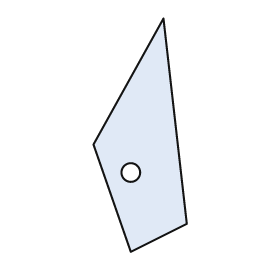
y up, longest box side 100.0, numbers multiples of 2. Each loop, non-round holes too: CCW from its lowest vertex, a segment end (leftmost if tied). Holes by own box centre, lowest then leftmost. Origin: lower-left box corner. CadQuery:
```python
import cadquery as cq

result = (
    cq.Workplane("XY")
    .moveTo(16.0, 0.0)
    .lineTo(40.0, 12.0)
    .lineTo(30.0, 100.0)
    .lineTo(0.0, 46.0)
    .close()
    .moveTo(16.0, 34.0)
    .circle(4.0)
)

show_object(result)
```